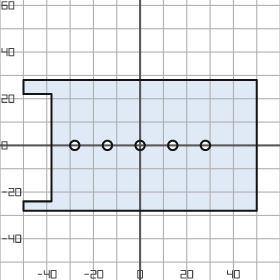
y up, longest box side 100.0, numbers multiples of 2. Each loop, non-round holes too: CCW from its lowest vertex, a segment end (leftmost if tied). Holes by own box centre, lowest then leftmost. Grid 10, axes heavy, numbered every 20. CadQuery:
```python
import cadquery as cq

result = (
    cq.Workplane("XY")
    .moveTo(-50.0, -28.0)
    .lineTo(50.0, -28.0)
    .lineTo(50.0, 28.0)
    .lineTo(-50.0, 28.0)
    .lineTo(-50.0, 22.0)
    .lineTo(-38.0, 22.0)
    .lineTo(-38.0, -24.0)
    .lineTo(-50.0, -24.0)
    .close()
    .moveTo(-28.0, 0.0)
    .circle(2.0)
    .moveTo(-14.0, 0.0)
    .circle(2.0)
    .moveTo(0.0, 0.0)
    .circle(2.0)
    .moveTo(14.0, 0.0)
    .circle(2.0)
    .moveTo(28.0, 0.0)
    .circle(2.0)
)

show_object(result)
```